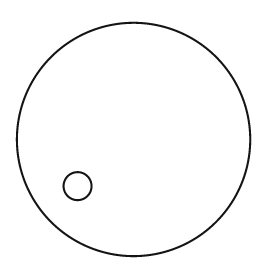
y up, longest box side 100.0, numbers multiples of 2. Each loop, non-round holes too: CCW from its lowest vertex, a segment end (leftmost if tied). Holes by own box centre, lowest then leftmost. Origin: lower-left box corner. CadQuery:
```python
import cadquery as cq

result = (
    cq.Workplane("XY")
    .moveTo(50.0, 50.0)
    .circle(50.0)
    .moveTo(26.0, 30.0)
    .circle(6.0)
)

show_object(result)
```